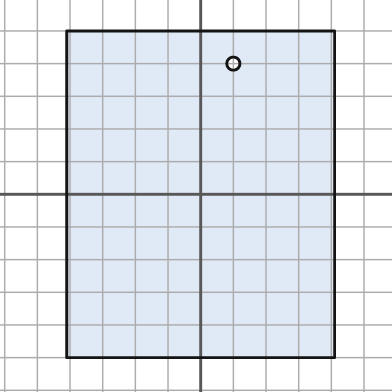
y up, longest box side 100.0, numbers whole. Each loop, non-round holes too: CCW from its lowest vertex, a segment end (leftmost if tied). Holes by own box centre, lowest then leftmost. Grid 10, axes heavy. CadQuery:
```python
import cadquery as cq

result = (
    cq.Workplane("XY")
    .moveTo(-41.0, -50.0)
    .lineTo(41.0, -50.0)
    .lineTo(41.0, 50.0)
    .lineTo(-41.0, 50.0)
    .close()
    .moveTo(10.0, 40.0)
    .circle(2.0)
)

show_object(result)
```